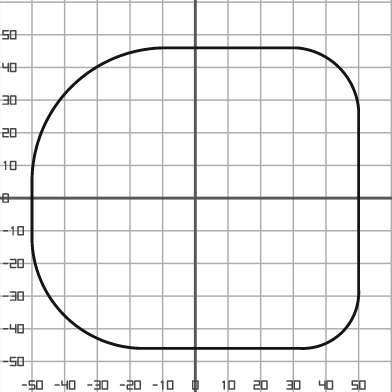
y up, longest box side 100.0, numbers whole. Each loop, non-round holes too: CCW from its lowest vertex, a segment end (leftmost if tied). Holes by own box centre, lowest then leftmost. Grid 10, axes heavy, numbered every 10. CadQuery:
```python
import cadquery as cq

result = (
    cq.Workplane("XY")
    .moveTo(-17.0, -46.0)
    .lineTo(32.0, -46.0)
    .threePointArc((45.0, -41.0), (50.0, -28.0))
    .lineTo(50.0, 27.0)
    .threePointArc((44.0, 40.0), (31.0, 46.0))
    .lineTo(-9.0, 46.0)
    .threePointArc((-38.0, 34.0), (-50.0, 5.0))
    .lineTo(-50.0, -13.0)
    .threePointArc((-40.0, -36.0), (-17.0, -46.0))
    .close()
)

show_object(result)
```